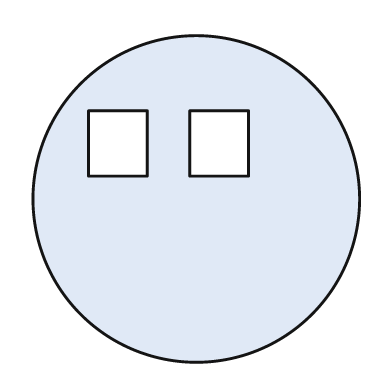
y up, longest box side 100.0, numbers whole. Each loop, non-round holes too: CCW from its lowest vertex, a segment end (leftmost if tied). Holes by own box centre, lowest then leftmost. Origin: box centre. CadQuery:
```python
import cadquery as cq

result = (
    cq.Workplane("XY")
    .moveTo(0.0, 0.0)
    .circle(50.0)
    .moveTo(-33.0, 7.0)
    .lineTo(-15.0, 7.0)
    .lineTo(-15.0, 27.0)
    .lineTo(-33.0, 27.0)
    .close()
    .moveTo(-2.0, 7.0)
    .lineTo(16.0, 7.0)
    .lineTo(16.0, 27.0)
    .lineTo(-2.0, 27.0)
    .close()
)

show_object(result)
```